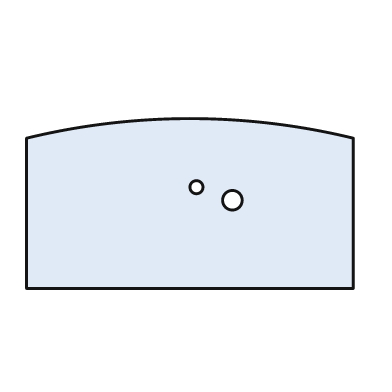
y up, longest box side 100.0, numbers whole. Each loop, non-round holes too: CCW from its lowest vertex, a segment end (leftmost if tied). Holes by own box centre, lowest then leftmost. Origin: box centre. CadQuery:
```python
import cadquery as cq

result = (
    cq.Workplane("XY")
    .moveTo(-50.0, -26.0)
    .lineTo(50.0, -26.0)
    .lineTo(50.0, 20.0)
    .threePointArc((0.0, 26.0), (-50.0, 20.0))
    .close()
    .moveTo(13.0, 1.0)
    .circle(3.0)
    .moveTo(2.0, 5.0)
    .circle(2.0)
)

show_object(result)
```